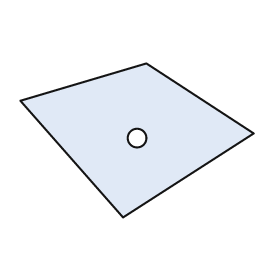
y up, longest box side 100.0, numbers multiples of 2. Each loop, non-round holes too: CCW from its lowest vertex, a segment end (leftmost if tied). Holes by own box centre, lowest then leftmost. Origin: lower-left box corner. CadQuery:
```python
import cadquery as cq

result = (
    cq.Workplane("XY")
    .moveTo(44.0, 0.0)
    .lineTo(100.0, 36.0)
    .lineTo(54.0, 66.0)
    .lineTo(0.0, 50.0)
    .close()
    .moveTo(50.0, 34.0)
    .circle(4.0)
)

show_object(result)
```